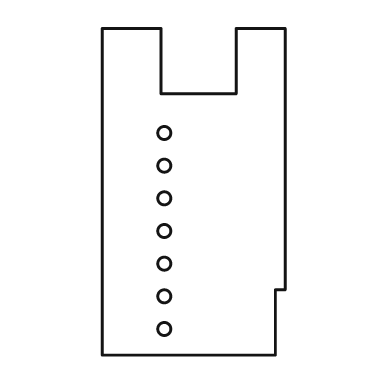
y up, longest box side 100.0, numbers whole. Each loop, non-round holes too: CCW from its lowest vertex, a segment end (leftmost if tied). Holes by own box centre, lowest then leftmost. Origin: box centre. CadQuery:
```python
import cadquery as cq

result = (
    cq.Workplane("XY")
    .moveTo(-28.0, -50.0)
    .lineTo(25.0, -50.0)
    .lineTo(25.0, -30.0)
    .lineTo(28.0, -30.0)
    .lineTo(28.0, 50.0)
    .lineTo(13.0, 50.0)
    .lineTo(13.0, 30.0)
    .lineTo(-10.0, 30.0)
    .lineTo(-10.0, 50.0)
    .lineTo(-28.0, 50.0)
    .close()
    .moveTo(-9.0, -42.0)
    .circle(2.0)
    .moveTo(-9.0, -32.0)
    .circle(2.0)
    .moveTo(-9.0, -22.0)
    .circle(2.0)
    .moveTo(-9.0, -12.0)
    .circle(2.0)
    .moveTo(-9.0, -2.0)
    .circle(2.0)
    .moveTo(-9.0, 8.0)
    .circle(2.0)
    .moveTo(-9.0, 18.0)
    .circle(2.0)
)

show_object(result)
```